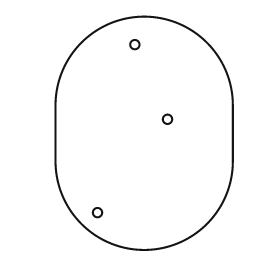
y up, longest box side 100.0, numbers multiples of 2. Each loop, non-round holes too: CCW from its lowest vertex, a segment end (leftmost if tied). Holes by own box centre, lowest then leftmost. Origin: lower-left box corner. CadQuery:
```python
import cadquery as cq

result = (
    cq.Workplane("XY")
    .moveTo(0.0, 38.0)
    .threePointArc((38.0, 0.0), (76.0, 38.0))
    .lineTo(76.0, 62.0)
    .threePointArc((38.0, 100.0), (0.0, 62.0))
    .close()
    .moveTo(18.0, 16.0)
    .circle(2.0)
    .moveTo(48.0, 56.0)
    .circle(2.0)
    .moveTo(34.0, 88.0)
    .circle(2.0)
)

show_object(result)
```